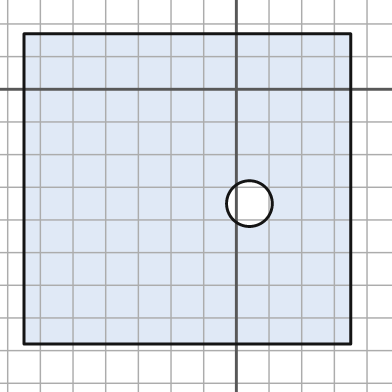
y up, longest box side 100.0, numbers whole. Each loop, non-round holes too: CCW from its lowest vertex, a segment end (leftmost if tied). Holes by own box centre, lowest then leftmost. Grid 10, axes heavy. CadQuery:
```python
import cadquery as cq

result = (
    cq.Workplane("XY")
    .moveTo(-65.0, -78.0)
    .lineTo(35.0, -78.0)
    .lineTo(35.0, 17.0)
    .lineTo(-65.0, 17.0)
    .close()
    .moveTo(4.0, -35.0)
    .circle(7.0)
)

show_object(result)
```